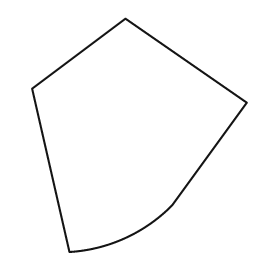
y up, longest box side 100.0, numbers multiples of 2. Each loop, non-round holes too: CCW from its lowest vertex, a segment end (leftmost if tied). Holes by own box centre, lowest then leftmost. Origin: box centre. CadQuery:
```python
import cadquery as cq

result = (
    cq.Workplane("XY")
    .moveTo(-30.0, -50.0)
    .threePointArc((-6.0, -44.0), (14.0, -30.0))
    .lineTo(46.0, 14.0)
    .lineTo(-6.0, 50.0)
    .lineTo(-46.0, 20.0)
    .close()
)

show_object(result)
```